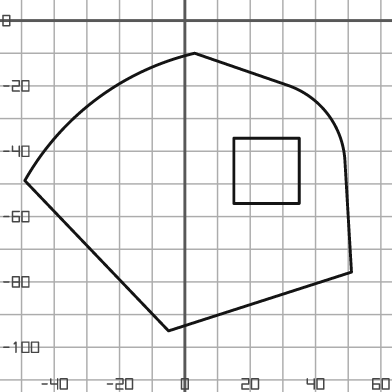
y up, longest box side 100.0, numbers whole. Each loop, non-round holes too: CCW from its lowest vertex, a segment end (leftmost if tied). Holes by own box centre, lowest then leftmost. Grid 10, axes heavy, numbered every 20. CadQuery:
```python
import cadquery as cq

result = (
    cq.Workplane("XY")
    .moveTo(-5.0, -95.0)
    .lineTo(51.0, -77.0)
    .lineTo(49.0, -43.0)
    .threePointArc((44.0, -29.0), (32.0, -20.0))
    .lineTo(3.0, -10.0)
    .threePointArc((-27.0, -24.0), (-49.0, -49.0))
    .close()
    .moveTo(15.0, -56.0)
    .lineTo(35.0, -56.0)
    .lineTo(35.0, -36.0)
    .lineTo(15.0, -36.0)
    .close()
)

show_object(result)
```